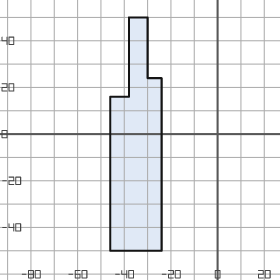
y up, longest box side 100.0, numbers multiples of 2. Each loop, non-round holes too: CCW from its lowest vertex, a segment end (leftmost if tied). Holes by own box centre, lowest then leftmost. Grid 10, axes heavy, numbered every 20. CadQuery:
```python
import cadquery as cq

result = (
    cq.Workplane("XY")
    .moveTo(-46.0, -50.0)
    .lineTo(-24.0, -50.0)
    .lineTo(-24.0, 24.0)
    .lineTo(-30.0, 24.0)
    .lineTo(-30.0, 50.0)
    .lineTo(-38.0, 50.0)
    .lineTo(-38.0, 16.0)
    .lineTo(-46.0, 16.0)
    .close()
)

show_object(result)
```